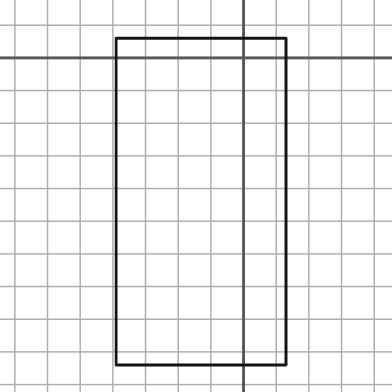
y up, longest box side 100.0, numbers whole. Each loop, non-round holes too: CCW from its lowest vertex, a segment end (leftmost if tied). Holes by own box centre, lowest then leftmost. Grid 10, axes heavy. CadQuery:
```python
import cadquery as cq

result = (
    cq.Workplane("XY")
    .moveTo(-39.0, -94.0)
    .lineTo(13.0, -94.0)
    .lineTo(13.0, 6.0)
    .lineTo(-39.0, 6.0)
    .close()
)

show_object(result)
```